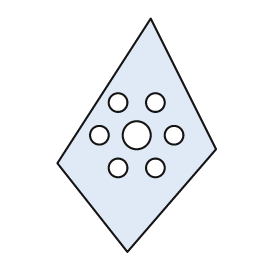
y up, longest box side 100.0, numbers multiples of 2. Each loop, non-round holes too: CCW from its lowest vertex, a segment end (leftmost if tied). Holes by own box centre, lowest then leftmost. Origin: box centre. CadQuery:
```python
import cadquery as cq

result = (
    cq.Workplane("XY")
    .moveTo(-4.0, -50.0)
    .lineTo(34.0, -6.0)
    .lineTo(6.0, 50.0)
    .lineTo(-34.0, -12.0)
    .close()
    .moveTo(-8.0, -14.0)
    .circle(4.0)
    .moveTo(8.0, -14.0)
    .circle(4.0)
    .moveTo(-16.0, 0.0)
    .circle(4.0)
    .moveTo(0.0, 0.0)
    .circle(6.0)
    .moveTo(16.0, 0.0)
    .circle(4.0)
    .moveTo(-8.0, 14.0)
    .circle(4.0)
    .moveTo(8.0, 14.0)
    .circle(4.0)
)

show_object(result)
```